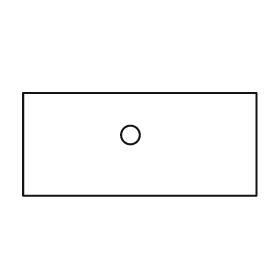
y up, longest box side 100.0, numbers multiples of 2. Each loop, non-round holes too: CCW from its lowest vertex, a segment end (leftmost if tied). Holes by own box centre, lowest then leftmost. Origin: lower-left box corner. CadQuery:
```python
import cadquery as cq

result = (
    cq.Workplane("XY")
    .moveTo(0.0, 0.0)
    .lineTo(100.0, 0.0)
    .lineTo(100.0, 44.0)
    .lineTo(0.0, 44.0)
    .close()
    .moveTo(46.0, 26.0)
    .circle(4.0)
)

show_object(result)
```